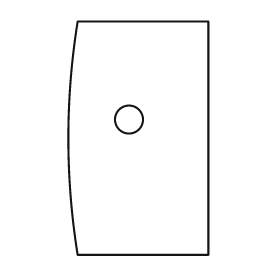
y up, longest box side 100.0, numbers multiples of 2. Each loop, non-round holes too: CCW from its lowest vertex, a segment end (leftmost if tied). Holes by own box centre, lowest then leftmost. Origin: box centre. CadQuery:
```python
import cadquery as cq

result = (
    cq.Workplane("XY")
    .moveTo(-26.0, -50.0)
    .lineTo(30.0, -50.0)
    .lineTo(30.0, 50.0)
    .lineTo(-26.0, 50.0)
    .threePointArc((-30.0, 0.0), (-26.0, -50.0))
    .close()
    .moveTo(-4.0, 8.0)
    .circle(6.0)
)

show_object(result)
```